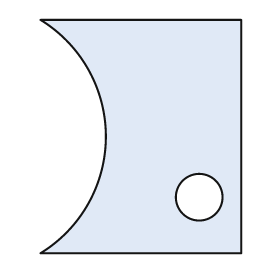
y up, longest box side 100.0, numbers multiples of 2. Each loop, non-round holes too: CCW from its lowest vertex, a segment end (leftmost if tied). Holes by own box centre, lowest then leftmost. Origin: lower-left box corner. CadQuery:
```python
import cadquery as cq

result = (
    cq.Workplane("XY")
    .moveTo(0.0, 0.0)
    .lineTo(86.0, 0.0)
    .lineTo(86.0, 100.0)
    .lineTo(0.0, 100.0)
    .threePointArc((28.0, 50.0), (0.0, 0.0))
    .close()
    .moveTo(68.0, 24.0)
    .circle(10.0)
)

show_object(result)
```